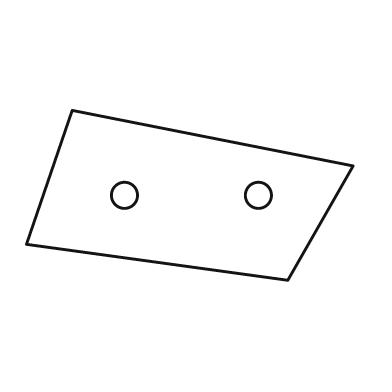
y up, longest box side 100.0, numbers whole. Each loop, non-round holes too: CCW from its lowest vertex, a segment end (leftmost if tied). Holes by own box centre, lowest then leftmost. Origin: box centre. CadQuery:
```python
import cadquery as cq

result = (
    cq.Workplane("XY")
    .moveTo(30.0, -26.0)
    .lineTo(50.0, 9.0)
    .lineTo(-36.0, 26.0)
    .lineTo(-50.0, -15.0)
    .close()
    .moveTo(-20.0, 0.0)
    .circle(4.0)
    .moveTo(21.0, 0.0)
    .circle(4.0)
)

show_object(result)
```